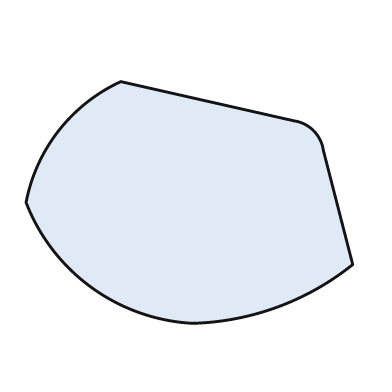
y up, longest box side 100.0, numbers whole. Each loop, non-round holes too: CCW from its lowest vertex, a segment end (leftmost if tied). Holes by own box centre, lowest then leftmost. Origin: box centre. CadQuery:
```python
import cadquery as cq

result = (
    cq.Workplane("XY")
    .moveTo(1.0, -37.0)
    .threePointArc((27.0, -32.0), (50.0, -19.0))
    .lineTo(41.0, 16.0)
    .threePointArc((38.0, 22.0), (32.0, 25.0))
    .lineTo(-21.0, 37.0)
    .threePointArc((-40.0, 22.0), (-50.0, 0.0))
    .threePointArc((-30.0, -26.0), (1.0, -37.0))
    .close()
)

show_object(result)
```